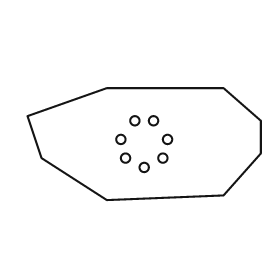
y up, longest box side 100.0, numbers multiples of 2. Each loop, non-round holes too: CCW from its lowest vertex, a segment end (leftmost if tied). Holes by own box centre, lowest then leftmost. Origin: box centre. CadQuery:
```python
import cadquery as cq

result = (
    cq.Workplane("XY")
    .moveTo(-16.0, -24.0)
    .lineTo(34.0, -22.0)
    .lineTo(50.0, -4.0)
    .lineTo(50.0, 10.0)
    .lineTo(34.0, 24.0)
    .lineTo(-16.0, 24.0)
    .lineTo(-50.0, 12.0)
    .lineTo(-44.0, -6.0)
    .close()
    .moveTo(0.0, -10.0)
    .circle(2.0)
    .moveTo(-8.0, -6.0)
    .circle(2.0)
    .moveTo(8.0, -6.0)
    .circle(2.0)
    .moveTo(-10.0, 2.0)
    .circle(2.0)
    .moveTo(10.0, 2.0)
    .circle(2.0)
    .moveTo(-4.0, 10.0)
    .circle(2.0)
    .moveTo(4.0, 10.0)
    .circle(2.0)
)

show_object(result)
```